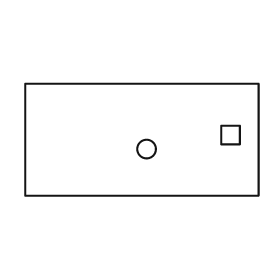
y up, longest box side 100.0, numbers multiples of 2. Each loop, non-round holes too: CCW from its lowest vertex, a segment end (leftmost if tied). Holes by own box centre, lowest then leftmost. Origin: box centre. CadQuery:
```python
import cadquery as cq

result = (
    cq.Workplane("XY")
    .moveTo(-50.0, -24.0)
    .lineTo(50.0, -24.0)
    .lineTo(50.0, 24.0)
    .lineTo(-50.0, 24.0)
    .close()
    .moveTo(2.0, -4.0)
    .circle(4.0)
    .moveTo(34.0, -2.0)
    .lineTo(42.0, -2.0)
    .lineTo(42.0, 6.0)
    .lineTo(34.0, 6.0)
    .close()
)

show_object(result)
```